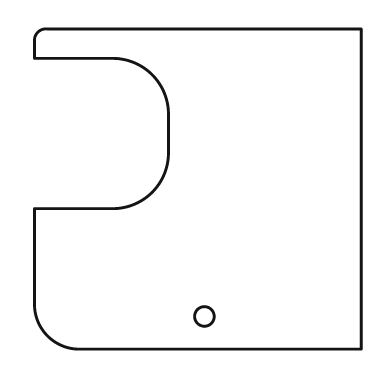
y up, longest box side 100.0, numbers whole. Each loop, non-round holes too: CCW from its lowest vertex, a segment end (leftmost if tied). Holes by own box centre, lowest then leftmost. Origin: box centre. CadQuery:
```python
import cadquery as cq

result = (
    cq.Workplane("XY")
    .moveTo(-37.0, -49.0)
    .lineTo(50.0, -49.0)
    .lineTo(50.0, 49.0)
    .lineTo(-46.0, 49.0)
    .threePointArc((-49.0, 48.0), (-50.0, 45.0))
    .lineTo(-50.0, 40.0)
    .lineTo(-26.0, 40.0)
    .threePointArc((-14.0, 35.0), (-9.0, 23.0))
    .lineTo(-9.0, 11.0)
    .threePointArc((-14.0, -1.0), (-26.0, -6.0))
    .lineTo(-50.0, -6.0)
    .lineTo(-50.0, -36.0)
    .threePointArc((-46.0, -45.0), (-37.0, -49.0))
    .close()
    .moveTo(2.0, -39.0)
    .circle(3.0)
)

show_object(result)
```